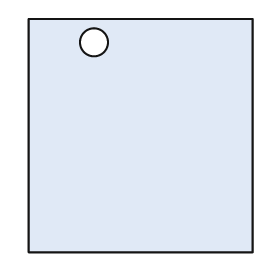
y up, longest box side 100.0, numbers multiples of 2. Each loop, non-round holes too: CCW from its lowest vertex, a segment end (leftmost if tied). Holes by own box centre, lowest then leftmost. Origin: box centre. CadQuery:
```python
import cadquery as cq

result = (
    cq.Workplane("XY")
    .moveTo(-48.0, -50.0)
    .lineTo(48.0, -50.0)
    .lineTo(48.0, 50.0)
    .lineTo(-48.0, 50.0)
    .close()
    .moveTo(-20.0, 40.0)
    .circle(6.0)
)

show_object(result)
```